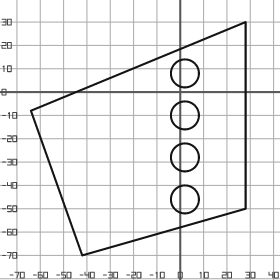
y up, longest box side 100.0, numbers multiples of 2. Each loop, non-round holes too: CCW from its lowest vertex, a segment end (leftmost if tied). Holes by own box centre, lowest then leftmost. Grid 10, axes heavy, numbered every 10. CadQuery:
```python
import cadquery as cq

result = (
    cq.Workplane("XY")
    .moveTo(-42.0, -70.0)
    .lineTo(28.0, -50.0)
    .lineTo(28.0, 30.0)
    .lineTo(-64.0, -8.0)
    .close()
    .moveTo(2.0, -46.0)
    .circle(6.0)
    .moveTo(2.0, -28.0)
    .circle(6.0)
    .moveTo(2.0, -10.0)
    .circle(6.0)
    .moveTo(2.0, 8.0)
    .circle(6.0)
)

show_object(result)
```